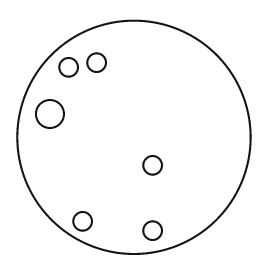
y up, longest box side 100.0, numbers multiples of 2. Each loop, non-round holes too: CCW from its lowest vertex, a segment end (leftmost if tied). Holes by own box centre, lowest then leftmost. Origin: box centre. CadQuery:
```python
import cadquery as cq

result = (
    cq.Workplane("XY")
    .moveTo(0.0, 0.0)
    .circle(50.0)
    .moveTo(8.0, -40.0)
    .circle(4.0)
    .moveTo(-22.0, -36.0)
    .circle(4.0)
    .moveTo(8.0, -12.0)
    .circle(4.0)
    .moveTo(-36.0, 10.0)
    .circle(6.0)
    .moveTo(-28.0, 30.0)
    .circle(4.0)
    .moveTo(-16.0, 32.0)
    .circle(4.0)
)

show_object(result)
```